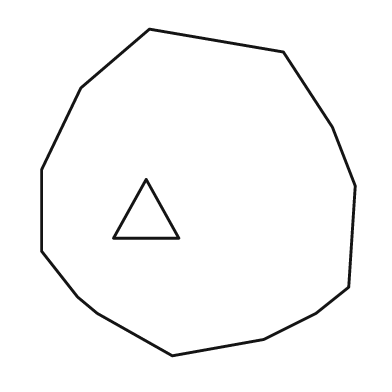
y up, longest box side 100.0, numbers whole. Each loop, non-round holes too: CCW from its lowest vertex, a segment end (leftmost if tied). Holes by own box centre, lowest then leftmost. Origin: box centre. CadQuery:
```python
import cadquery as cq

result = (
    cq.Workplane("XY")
    .moveTo(-8.0, -50.0)
    .lineTo(20.0, -45.0)
    .lineTo(36.0, -37.0)
    .lineTo(46.0, -29.0)
    .lineTo(48.0, 2.0)
    .lineTo(41.0, 20.0)
    .lineTo(26.0, 43.0)
    .lineTo(-15.0, 50.0)
    .lineTo(-36.0, 32.0)
    .lineTo(-48.0, 7.0)
    .lineTo(-48.0, -18.0)
    .lineTo(-37.0, -32.0)
    .lineTo(-31.0, -37.0)
    .close()
    .moveTo(-26.0, -14.0)
    .lineTo(-6.0, -14.0)
    .lineTo(-16.0, 4.0)
    .close()
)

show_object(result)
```